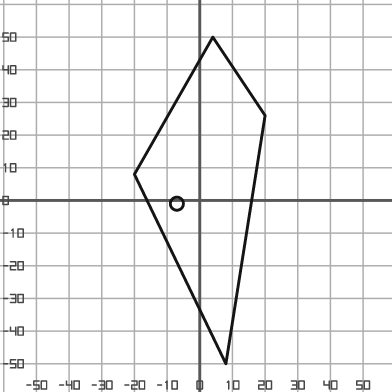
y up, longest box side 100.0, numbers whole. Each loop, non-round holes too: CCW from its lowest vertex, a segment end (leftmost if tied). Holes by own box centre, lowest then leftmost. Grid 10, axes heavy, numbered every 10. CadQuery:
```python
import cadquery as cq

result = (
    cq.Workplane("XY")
    .moveTo(8.0, -50.0)
    .lineTo(20.0, 26.0)
    .lineTo(4.0, 50.0)
    .lineTo(-20.0, 8.0)
    .close()
    .moveTo(-7.0, -1.0)
    .circle(2.0)
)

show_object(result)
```